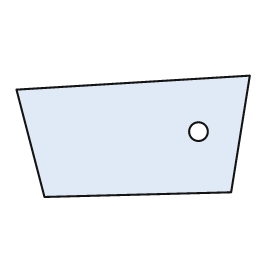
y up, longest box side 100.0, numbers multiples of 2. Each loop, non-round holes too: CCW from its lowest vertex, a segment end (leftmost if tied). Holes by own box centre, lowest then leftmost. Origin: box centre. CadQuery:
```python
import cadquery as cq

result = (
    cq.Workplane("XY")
    .moveTo(-38.0, -26.0)
    .lineTo(42.0, -24.0)
    .lineTo(50.0, 26.0)
    .lineTo(-50.0, 20.0)
    .close()
    .moveTo(28.0, 2.0)
    .circle(4.0)
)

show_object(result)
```